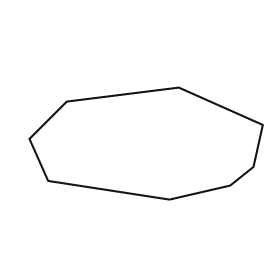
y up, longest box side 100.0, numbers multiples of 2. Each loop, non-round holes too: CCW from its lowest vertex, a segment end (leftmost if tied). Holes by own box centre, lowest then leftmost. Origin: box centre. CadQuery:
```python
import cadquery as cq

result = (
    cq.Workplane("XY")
    .moveTo(10.0, -24.0)
    .lineTo(36.0, -18.0)
    .lineTo(46.0, -10.0)
    .lineTo(50.0, 8.0)
    .lineTo(14.0, 24.0)
    .lineTo(-34.0, 18.0)
    .lineTo(-50.0, 2.0)
    .lineTo(-42.0, -16.0)
    .close()
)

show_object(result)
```